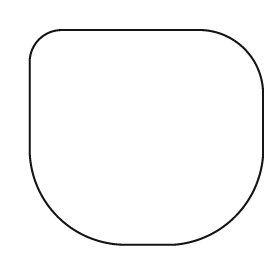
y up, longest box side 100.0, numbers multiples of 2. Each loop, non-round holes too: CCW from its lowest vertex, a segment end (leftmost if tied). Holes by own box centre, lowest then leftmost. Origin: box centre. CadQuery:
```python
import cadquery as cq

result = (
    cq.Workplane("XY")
    .moveTo(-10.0, -46.0)
    .lineTo(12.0, -46.0)
    .threePointArc((38.0, -34.0), (50.0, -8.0))
    .lineTo(50.0, 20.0)
    .threePointArc((42.0, 38.0), (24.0, 46.0))
    .lineTo(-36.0, 46.0)
    .threePointArc((-46.0, 42.0), (-50.0, 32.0))
    .lineTo(-50.0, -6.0)
    .threePointArc((-38.0, -34.0), (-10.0, -46.0))
    .close()
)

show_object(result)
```